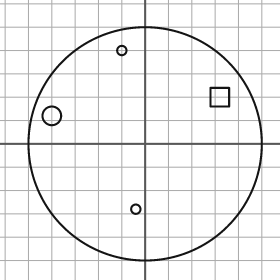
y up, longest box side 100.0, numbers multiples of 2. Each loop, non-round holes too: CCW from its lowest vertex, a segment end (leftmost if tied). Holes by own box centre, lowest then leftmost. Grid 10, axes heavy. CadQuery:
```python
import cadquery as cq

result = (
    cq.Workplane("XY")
    .moveTo(0.0, 0.0)
    .circle(50.0)
    .moveTo(-4.0, -28.0)
    .circle(2.0)
    .moveTo(-40.0, 12.0)
    .circle(4.0)
    .moveTo(28.0, 16.0)
    .lineTo(36.0, 16.0)
    .lineTo(36.0, 24.0)
    .lineTo(28.0, 24.0)
    .close()
    .moveTo(-10.0, 40.0)
    .circle(2.0)
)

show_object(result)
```